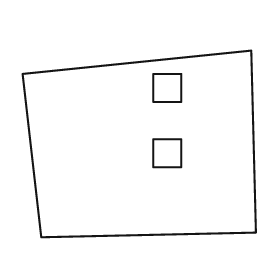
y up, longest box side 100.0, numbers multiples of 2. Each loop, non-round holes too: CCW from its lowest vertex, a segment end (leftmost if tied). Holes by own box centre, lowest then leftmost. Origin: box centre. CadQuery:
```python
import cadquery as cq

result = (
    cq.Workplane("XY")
    .moveTo(-42.0, -40.0)
    .lineTo(50.0, -38.0)
    .lineTo(48.0, 40.0)
    .lineTo(-50.0, 30.0)
    .close()
    .moveTo(6.0, -10.0)
    .lineTo(18.0, -10.0)
    .lineTo(18.0, 2.0)
    .lineTo(6.0, 2.0)
    .close()
    .moveTo(6.0, 18.0)
    .lineTo(18.0, 18.0)
    .lineTo(18.0, 30.0)
    .lineTo(6.0, 30.0)
    .close()
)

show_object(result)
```